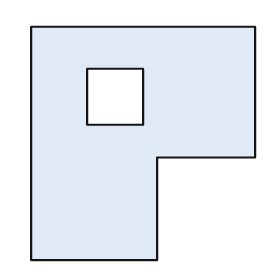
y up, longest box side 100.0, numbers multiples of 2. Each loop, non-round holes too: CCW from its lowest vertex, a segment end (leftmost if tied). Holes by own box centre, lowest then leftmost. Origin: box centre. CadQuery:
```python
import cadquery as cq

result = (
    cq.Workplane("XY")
    .moveTo(-48.0, -50.0)
    .lineTo(6.0, -50.0)
    .lineTo(6.0, -6.0)
    .lineTo(48.0, -6.0)
    .lineTo(48.0, 50.0)
    .lineTo(-48.0, 50.0)
    .close()
    .moveTo(-24.0, 8.0)
    .lineTo(0.0, 8.0)
    .lineTo(0.0, 32.0)
    .lineTo(-24.0, 32.0)
    .close()
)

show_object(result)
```